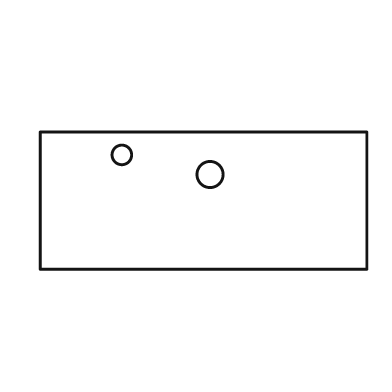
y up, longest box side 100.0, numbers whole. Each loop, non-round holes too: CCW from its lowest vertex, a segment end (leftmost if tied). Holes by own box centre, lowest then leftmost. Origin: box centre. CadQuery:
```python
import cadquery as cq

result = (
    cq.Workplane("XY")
    .moveTo(-50.0, -21.0)
    .lineTo(50.0, -21.0)
    .lineTo(50.0, 21.0)
    .lineTo(-50.0, 21.0)
    .close()
    .moveTo(2.0, 8.0)
    .circle(4.0)
    .moveTo(-25.0, 14.0)
    .circle(3.0)
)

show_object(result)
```